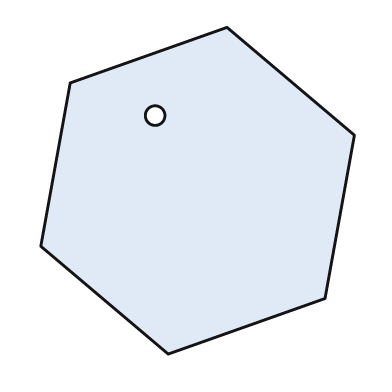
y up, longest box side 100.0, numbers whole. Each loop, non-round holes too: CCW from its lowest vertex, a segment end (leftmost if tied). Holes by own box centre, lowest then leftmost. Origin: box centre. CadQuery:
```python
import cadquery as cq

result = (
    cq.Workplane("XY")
    .moveTo(-9.0, -50.0)
    .lineTo(39.0, -33.0)
    .lineTo(48.0, 17.0)
    .lineTo(9.0, 50.0)
    .lineTo(-39.0, 33.0)
    .lineTo(-48.0, -17.0)
    .close()
    .moveTo(-13.0, 23.0)
    .circle(3.0)
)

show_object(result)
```